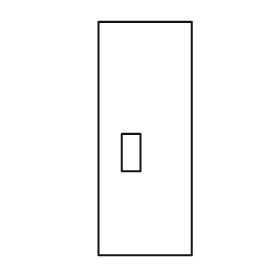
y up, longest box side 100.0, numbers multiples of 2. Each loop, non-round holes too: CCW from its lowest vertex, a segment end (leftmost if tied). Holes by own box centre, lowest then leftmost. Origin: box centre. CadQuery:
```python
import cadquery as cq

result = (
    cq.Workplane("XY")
    .moveTo(-20.0, -50.0)
    .lineTo(20.0, -50.0)
    .lineTo(20.0, 50.0)
    .lineTo(-20.0, 50.0)
    .close()
    .moveTo(-10.0, -14.0)
    .lineTo(-2.0, -14.0)
    .lineTo(-2.0, 2.0)
    .lineTo(-10.0, 2.0)
    .close()
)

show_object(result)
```